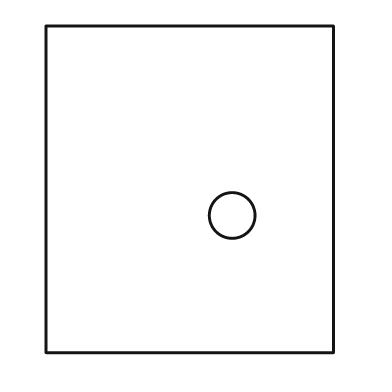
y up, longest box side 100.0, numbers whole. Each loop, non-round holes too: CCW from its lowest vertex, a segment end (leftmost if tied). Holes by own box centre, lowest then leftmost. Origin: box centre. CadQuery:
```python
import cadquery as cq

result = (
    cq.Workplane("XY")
    .moveTo(-44.0, -50.0)
    .lineTo(44.0, -50.0)
    .lineTo(44.0, 50.0)
    .lineTo(-44.0, 50.0)
    .close()
    .moveTo(13.0, -8.0)
    .circle(7.0)
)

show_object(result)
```